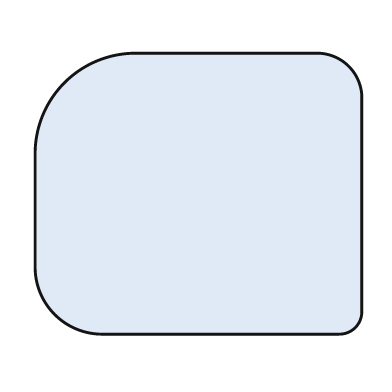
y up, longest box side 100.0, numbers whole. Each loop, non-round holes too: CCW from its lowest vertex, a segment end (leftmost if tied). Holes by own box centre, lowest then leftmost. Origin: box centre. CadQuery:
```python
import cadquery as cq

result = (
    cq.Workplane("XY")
    .moveTo(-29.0, -43.0)
    .lineTo(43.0, -43.0)
    .threePointArc((48.0, -41.0), (50.0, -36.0))
    .lineTo(50.0, 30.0)
    .threePointArc((46.0, 39.0), (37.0, 43.0))
    .lineTo(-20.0, 43.0)
    .threePointArc((-41.0, 34.0), (-50.0, 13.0))
    .lineTo(-50.0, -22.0)
    .threePointArc((-44.0, -37.0), (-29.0, -43.0))
    .close()
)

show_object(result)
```